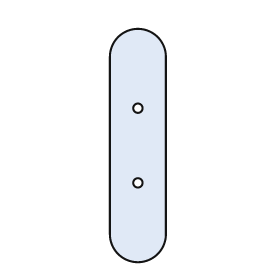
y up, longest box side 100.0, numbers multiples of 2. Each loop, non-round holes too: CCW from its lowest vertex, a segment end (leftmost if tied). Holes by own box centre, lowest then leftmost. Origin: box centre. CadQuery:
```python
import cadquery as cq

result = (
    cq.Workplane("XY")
    .moveTo(-12.0, -38.0)
    .threePointArc((0.0, -50.0), (12.0, -38.0))
    .lineTo(12.0, 38.0)
    .threePointArc((0.0, 50.0), (-12.0, 38.0))
    .close()
    .moveTo(0.0, -16.0)
    .circle(2.0)
    .moveTo(0.0, 16.0)
    .circle(2.0)
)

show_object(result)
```